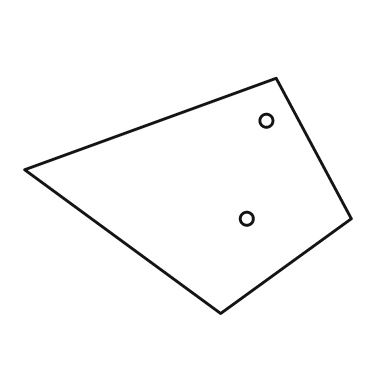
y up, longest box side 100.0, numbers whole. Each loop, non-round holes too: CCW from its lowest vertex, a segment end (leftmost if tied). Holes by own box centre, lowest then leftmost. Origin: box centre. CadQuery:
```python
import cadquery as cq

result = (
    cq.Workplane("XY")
    .moveTo(10.0, -36.0)
    .lineTo(50.0, -7.0)
    .lineTo(27.0, 36.0)
    .lineTo(-50.0, 8.0)
    .close()
    .moveTo(18.0, -7.0)
    .circle(2.0)
    .moveTo(24.0, 23.0)
    .circle(2.0)
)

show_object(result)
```